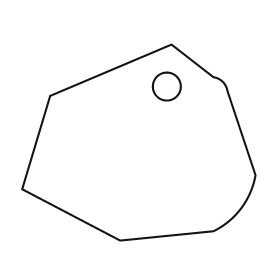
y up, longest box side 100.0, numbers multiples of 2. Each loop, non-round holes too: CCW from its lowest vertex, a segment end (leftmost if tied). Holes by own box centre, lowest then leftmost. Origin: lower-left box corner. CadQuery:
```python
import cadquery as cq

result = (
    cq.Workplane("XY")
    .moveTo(42.0, 0.0)
    .lineTo(82.0, 4.0)
    .threePointArc((94.0, 14.0), (100.0, 28.0))
    .lineTo(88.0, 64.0)
    .threePointArc((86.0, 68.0), (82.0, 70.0))
    .lineTo(64.0, 84.0)
    .lineTo(12.0, 62.0)
    .lineTo(0.0, 22.0)
    .close()
    .moveTo(62.0, 66.0)
    .circle(6.0)
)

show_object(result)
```